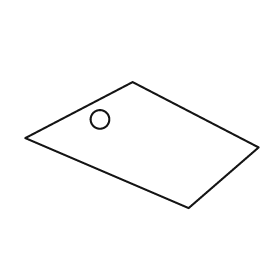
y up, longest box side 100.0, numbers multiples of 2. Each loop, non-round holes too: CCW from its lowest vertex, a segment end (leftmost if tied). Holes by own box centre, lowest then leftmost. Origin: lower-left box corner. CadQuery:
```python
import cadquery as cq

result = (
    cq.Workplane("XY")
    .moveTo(70.0, 0.0)
    .lineTo(100.0, 26.0)
    .lineTo(46.0, 54.0)
    .lineTo(0.0, 30.0)
    .close()
    .moveTo(32.0, 38.0)
    .circle(4.0)
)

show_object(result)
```